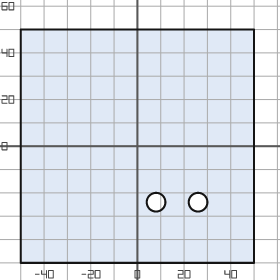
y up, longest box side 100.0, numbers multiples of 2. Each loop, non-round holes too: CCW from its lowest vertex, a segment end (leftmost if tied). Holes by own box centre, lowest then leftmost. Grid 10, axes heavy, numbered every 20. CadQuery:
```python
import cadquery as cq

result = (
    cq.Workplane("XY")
    .moveTo(-50.0, -50.0)
    .lineTo(50.0, -50.0)
    .lineTo(50.0, 50.0)
    .lineTo(-50.0, 50.0)
    .close()
    .moveTo(8.0, -24.0)
    .circle(4.0)
    .moveTo(26.0, -24.0)
    .circle(4.0)
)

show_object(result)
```